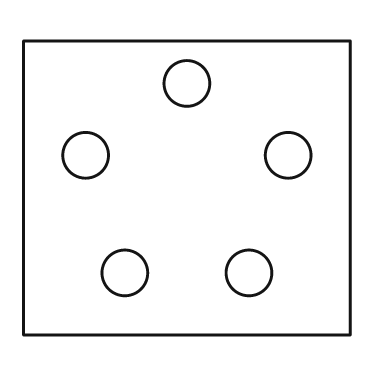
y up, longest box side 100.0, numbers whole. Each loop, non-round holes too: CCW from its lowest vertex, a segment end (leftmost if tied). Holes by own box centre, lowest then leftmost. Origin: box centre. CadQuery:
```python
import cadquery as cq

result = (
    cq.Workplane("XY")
    .moveTo(-50.0, -45.0)
    .lineTo(50.0, -45.0)
    .lineTo(50.0, 45.0)
    .lineTo(-50.0, 45.0)
    .close()
    .moveTo(-19.0, -26.0)
    .circle(7.0)
    .moveTo(19.0, -26.0)
    .circle(7.0)
    .moveTo(-31.0, 10.0)
    .circle(7.0)
    .moveTo(31.0, 10.0)
    .circle(7.0)
    .moveTo(0.0, 32.0)
    .circle(7.0)
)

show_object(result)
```